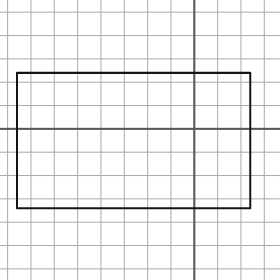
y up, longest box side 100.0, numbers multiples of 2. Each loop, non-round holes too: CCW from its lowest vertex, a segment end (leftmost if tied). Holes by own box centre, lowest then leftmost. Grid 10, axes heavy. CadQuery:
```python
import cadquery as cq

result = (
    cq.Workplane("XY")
    .moveTo(-76.0, -34.0)
    .lineTo(24.0, -34.0)
    .lineTo(24.0, 24.0)
    .lineTo(-76.0, 24.0)
    .close()
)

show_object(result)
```